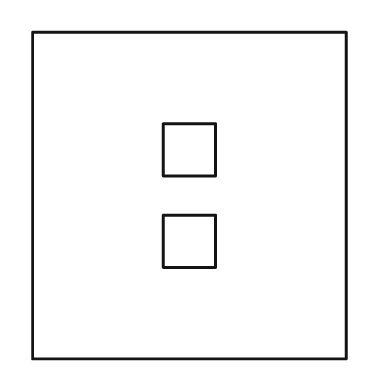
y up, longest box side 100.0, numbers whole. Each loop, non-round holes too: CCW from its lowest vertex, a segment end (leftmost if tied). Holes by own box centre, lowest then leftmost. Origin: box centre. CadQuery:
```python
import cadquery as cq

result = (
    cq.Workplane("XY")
    .moveTo(-48.0, -50.0)
    .lineTo(48.0, -50.0)
    .lineTo(48.0, 50.0)
    .lineTo(-48.0, 50.0)
    .close()
    .moveTo(-8.0, -22.0)
    .lineTo(8.0, -22.0)
    .lineTo(8.0, -6.0)
    .lineTo(-8.0, -6.0)
    .close()
    .moveTo(-8.0, 6.0)
    .lineTo(8.0, 6.0)
    .lineTo(8.0, 22.0)
    .lineTo(-8.0, 22.0)
    .close()
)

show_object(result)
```